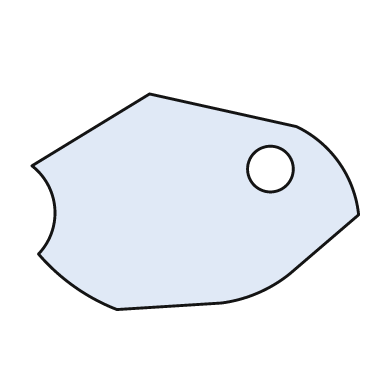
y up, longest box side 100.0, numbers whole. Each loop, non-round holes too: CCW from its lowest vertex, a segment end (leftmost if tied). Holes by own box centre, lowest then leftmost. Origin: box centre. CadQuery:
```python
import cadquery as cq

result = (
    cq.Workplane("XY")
    .moveTo(-24.0, -33.0)
    .lineTo(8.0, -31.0)
    .threePointArc((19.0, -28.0), (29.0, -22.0))
    .lineTo(50.0, -4.0)
    .threePointArc((44.0, 12.0), (31.0, 23.0))
    .lineTo(-14.0, 33.0)
    .lineTo(-50.0, 11.0)
    .threePointArc((-43.0, -2.0), (-48.0, -16.0))
    .threePointArc((-37.0, -26.0), (-24.0, -33.0))
    .close()
    .moveTo(23.0, 10.0)
    .circle(7.0)
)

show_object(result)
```